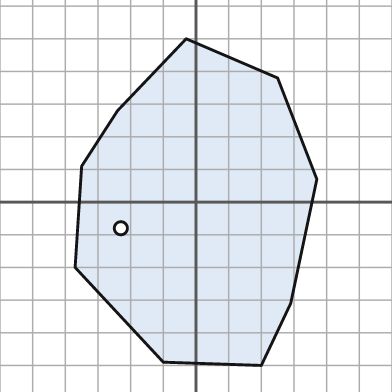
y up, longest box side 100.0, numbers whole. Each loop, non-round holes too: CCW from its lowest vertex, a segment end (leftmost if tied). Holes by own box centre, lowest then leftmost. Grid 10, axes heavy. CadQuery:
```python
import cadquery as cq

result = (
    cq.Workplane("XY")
    .moveTo(20.0, -50.0)
    .lineTo(29.0, -31.0)
    .lineTo(37.0, 7.0)
    .lineTo(25.0, 38.0)
    .lineTo(-3.0, 50.0)
    .lineTo(-24.0, 28.0)
    .lineTo(-35.0, 11.0)
    .lineTo(-37.0, -20.0)
    .lineTo(-10.0, -49.0)
    .close()
    .moveTo(-23.0, -8.0)
    .circle(2.0)
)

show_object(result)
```